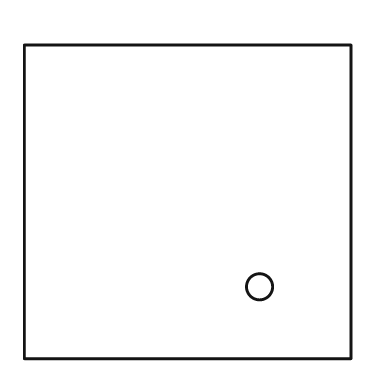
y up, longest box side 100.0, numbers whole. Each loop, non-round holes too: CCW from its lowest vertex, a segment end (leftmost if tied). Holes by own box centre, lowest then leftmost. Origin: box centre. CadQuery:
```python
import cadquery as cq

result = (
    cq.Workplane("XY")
    .moveTo(-50.0, -48.0)
    .lineTo(50.0, -48.0)
    .lineTo(50.0, 48.0)
    .lineTo(-50.0, 48.0)
    .close()
    .moveTo(22.0, -26.0)
    .circle(4.0)
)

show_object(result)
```